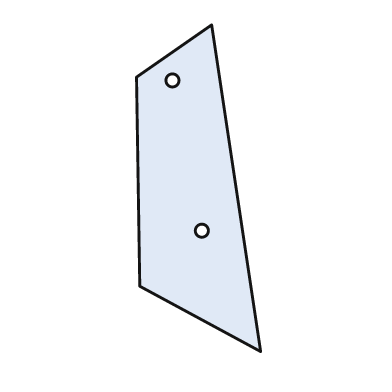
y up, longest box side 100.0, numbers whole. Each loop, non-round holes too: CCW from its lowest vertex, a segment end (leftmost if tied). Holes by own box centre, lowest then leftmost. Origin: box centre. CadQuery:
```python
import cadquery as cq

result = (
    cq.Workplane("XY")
    .moveTo(19.0, -50.0)
    .lineTo(4.0, 50.0)
    .lineTo(-19.0, 34.0)
    .lineTo(-18.0, -30.0)
    .close()
    .moveTo(1.0, -13.0)
    .circle(2.0)
    .moveTo(-8.0, 33.0)
    .circle(2.0)
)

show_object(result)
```